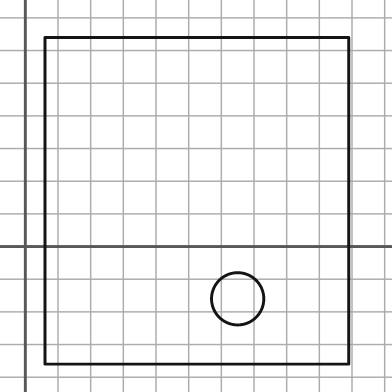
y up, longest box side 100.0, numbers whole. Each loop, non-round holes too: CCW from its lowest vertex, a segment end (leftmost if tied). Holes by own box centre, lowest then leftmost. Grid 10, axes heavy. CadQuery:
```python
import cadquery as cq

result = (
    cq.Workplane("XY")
    .moveTo(6.0, -36.0)
    .lineTo(99.0, -36.0)
    .lineTo(99.0, 64.0)
    .lineTo(6.0, 64.0)
    .close()
    .moveTo(65.0, -16.0)
    .circle(8.0)
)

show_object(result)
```